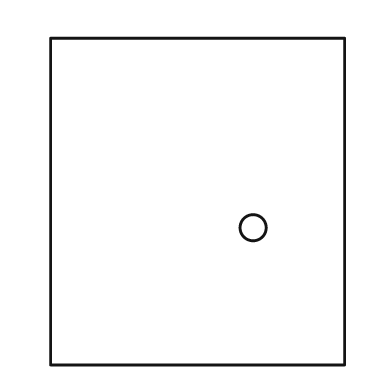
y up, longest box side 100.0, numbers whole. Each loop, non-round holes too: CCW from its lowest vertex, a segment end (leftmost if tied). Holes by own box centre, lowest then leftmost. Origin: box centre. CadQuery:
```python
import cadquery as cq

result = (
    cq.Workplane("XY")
    .moveTo(-45.0, -50.0)
    .lineTo(45.0, -50.0)
    .lineTo(45.0, 50.0)
    .lineTo(-45.0, 50.0)
    .close()
    .moveTo(17.0, -8.0)
    .circle(4.0)
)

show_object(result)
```